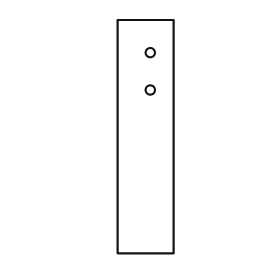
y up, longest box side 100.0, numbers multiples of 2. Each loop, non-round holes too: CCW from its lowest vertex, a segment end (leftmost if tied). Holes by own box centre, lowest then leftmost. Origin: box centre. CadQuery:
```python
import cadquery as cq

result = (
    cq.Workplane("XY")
    .moveTo(-12.0, -50.0)
    .lineTo(12.0, -50.0)
    .lineTo(12.0, 50.0)
    .lineTo(-12.0, 50.0)
    .close()
    .moveTo(2.0, 20.0)
    .circle(2.0)
    .moveTo(2.0, 36.0)
    .circle(2.0)
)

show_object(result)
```